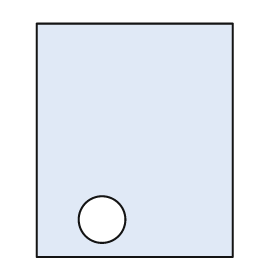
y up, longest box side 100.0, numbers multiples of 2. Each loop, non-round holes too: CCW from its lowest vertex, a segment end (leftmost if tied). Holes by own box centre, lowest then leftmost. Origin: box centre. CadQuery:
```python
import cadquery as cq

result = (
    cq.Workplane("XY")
    .moveTo(-42.0, -50.0)
    .lineTo(42.0, -50.0)
    .lineTo(42.0, 50.0)
    .lineTo(-42.0, 50.0)
    .close()
    .moveTo(-14.0, -34.0)
    .circle(10.0)
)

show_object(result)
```